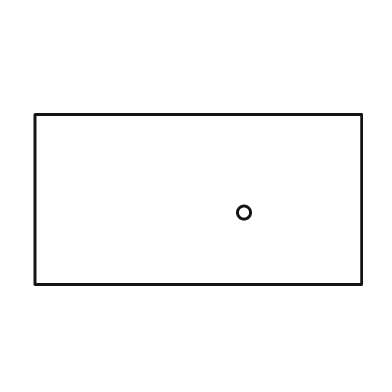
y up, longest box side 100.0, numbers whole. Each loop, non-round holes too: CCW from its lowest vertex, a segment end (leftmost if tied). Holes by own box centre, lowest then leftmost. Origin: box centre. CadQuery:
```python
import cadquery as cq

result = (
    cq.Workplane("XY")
    .moveTo(-50.0, -26.0)
    .lineTo(50.0, -26.0)
    .lineTo(50.0, 26.0)
    .lineTo(-50.0, 26.0)
    .close()
    .moveTo(14.0, -4.0)
    .circle(2.0)
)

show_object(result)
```